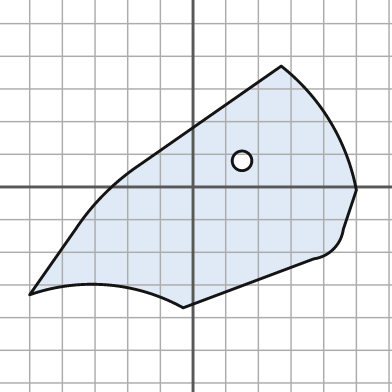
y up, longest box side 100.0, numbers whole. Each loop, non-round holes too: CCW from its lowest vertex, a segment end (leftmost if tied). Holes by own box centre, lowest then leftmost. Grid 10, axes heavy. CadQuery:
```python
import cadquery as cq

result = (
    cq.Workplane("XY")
    .moveTo(-3.0, -37.0)
    .lineTo(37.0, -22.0)
    .threePointArc((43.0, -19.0), (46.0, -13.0))
    .lineTo(50.0, -1.0)
    .threePointArc((42.0, 20.0), (27.0, 37.0))
    .lineTo(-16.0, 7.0)
    .threePointArc((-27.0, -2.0), (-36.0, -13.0))
    .lineTo(-50.0, -33.0)
    .threePointArc((-26.0, -30.0), (-3.0, -37.0))
    .close()
    .moveTo(15.0, 8.0)
    .circle(3.0)
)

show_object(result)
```